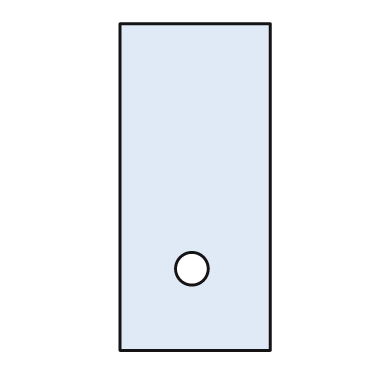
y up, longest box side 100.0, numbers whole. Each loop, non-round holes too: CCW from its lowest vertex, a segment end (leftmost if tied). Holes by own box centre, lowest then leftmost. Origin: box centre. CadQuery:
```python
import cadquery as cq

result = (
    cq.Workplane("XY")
    .moveTo(-23.0, -50.0)
    .lineTo(23.0, -50.0)
    .lineTo(23.0, 50.0)
    .lineTo(-23.0, 50.0)
    .close()
    .moveTo(-1.0, -25.0)
    .circle(5.0)
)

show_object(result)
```